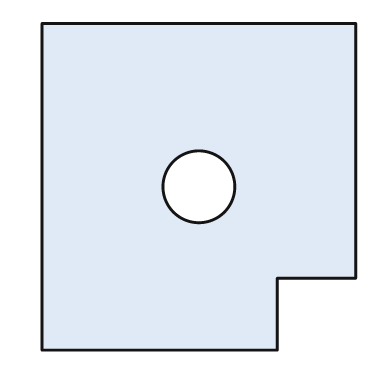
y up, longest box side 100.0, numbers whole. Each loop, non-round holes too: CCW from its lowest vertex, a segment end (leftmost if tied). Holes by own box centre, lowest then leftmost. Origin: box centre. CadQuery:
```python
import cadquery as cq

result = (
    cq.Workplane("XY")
    .moveTo(-48.0, -50.0)
    .lineTo(24.0, -50.0)
    .lineTo(24.0, -28.0)
    .lineTo(48.0, -28.0)
    .lineTo(48.0, 50.0)
    .lineTo(-48.0, 50.0)
    .close()
    .moveTo(0.0, 0.0)
    .circle(11.0)
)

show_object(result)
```